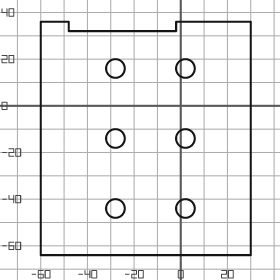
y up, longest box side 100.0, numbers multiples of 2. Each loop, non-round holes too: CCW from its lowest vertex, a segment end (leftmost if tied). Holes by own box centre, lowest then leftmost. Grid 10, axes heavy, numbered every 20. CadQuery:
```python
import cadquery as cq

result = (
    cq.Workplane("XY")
    .moveTo(-60.0, -64.0)
    .lineTo(30.0, -64.0)
    .lineTo(30.0, 36.0)
    .lineTo(-2.0, 36.0)
    .lineTo(-2.0, 32.0)
    .lineTo(-48.0, 32.0)
    .lineTo(-48.0, 36.0)
    .lineTo(-60.0, 36.0)
    .close()
    .moveTo(-28.0, -44.0)
    .circle(4.0)
    .moveTo(2.0, -44.0)
    .circle(4.0)
    .moveTo(-28.0, -14.0)
    .circle(4.0)
    .moveTo(2.0, -14.0)
    .circle(4.0)
    .moveTo(-28.0, 16.0)
    .circle(4.0)
    .moveTo(2.0, 16.0)
    .circle(4.0)
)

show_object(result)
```